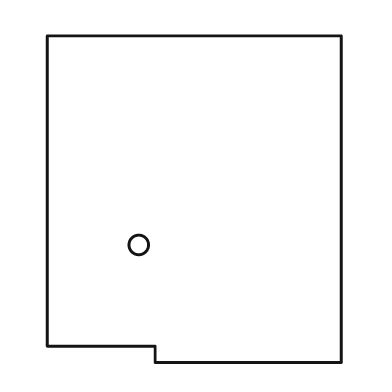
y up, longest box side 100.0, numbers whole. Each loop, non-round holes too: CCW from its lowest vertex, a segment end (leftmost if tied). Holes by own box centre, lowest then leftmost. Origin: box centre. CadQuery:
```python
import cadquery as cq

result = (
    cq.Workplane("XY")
    .moveTo(-12.0, -50.0)
    .lineTo(45.0, -50.0)
    .lineTo(45.0, 50.0)
    .lineTo(-45.0, 50.0)
    .lineTo(-45.0, -45.0)
    .lineTo(-12.0, -45.0)
    .close()
    .moveTo(-17.0, -14.0)
    .circle(3.0)
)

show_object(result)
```